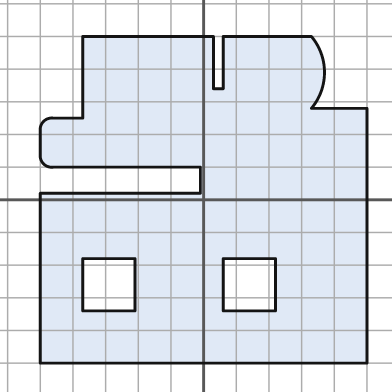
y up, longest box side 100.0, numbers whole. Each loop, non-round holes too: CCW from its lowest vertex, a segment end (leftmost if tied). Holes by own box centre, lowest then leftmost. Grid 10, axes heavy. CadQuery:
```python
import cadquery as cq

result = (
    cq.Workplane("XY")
    .moveTo(-50.0, -50.0)
    .lineTo(50.0, -50.0)
    .lineTo(50.0, 28.0)
    .lineTo(33.0, 28.0)
    .threePointArc((37.0, 39.0), (33.0, 50.0))
    .lineTo(6.0, 50.0)
    .lineTo(6.0, 34.0)
    .lineTo(3.0, 34.0)
    .lineTo(3.0, 50.0)
    .lineTo(-37.0, 50.0)
    .lineTo(-37.0, 25.0)
    .lineTo(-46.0, 25.0)
    .threePointArc((-49.0, 24.0), (-50.0, 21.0))
    .lineTo(-50.0, 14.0)
    .threePointArc((-49.0, 11.0), (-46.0, 10.0))
    .lineTo(-1.0, 10.0)
    .lineTo(-1.0, 2.0)
    .lineTo(-50.0, 2.0)
    .close()
    .moveTo(-37.0, -34.0)
    .lineTo(-21.0, -34.0)
    .lineTo(-21.0, -18.0)
    .lineTo(-37.0, -18.0)
    .close()
    .moveTo(6.0, -34.0)
    .lineTo(22.0, -34.0)
    .lineTo(22.0, -18.0)
    .lineTo(6.0, -18.0)
    .close()
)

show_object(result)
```